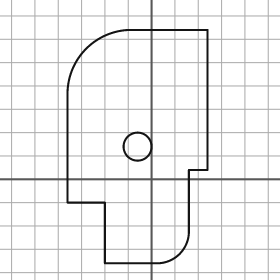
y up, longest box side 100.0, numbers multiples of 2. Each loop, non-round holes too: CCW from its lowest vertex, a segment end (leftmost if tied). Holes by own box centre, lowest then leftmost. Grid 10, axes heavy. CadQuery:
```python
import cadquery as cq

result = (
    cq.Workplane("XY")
    .moveTo(-20.0, -36.0)
    .lineTo(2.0, -36.0)
    .threePointArc((12.0, -32.0), (16.0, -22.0))
    .lineTo(16.0, 4.0)
    .lineTo(24.0, 4.0)
    .lineTo(24.0, 64.0)
    .lineTo(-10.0, 64.0)
    .threePointArc((-28.0, 56.0), (-36.0, 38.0))
    .lineTo(-36.0, -10.0)
    .lineTo(-20.0, -10.0)
    .close()
    .moveTo(-6.0, 14.0)
    .circle(6.0)
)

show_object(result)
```